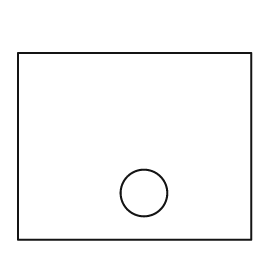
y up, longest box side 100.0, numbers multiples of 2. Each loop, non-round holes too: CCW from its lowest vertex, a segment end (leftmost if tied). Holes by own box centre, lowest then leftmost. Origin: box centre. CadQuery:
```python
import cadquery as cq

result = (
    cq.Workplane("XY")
    .moveTo(-50.0, -40.0)
    .lineTo(50.0, -40.0)
    .lineTo(50.0, 40.0)
    .lineTo(-50.0, 40.0)
    .close()
    .moveTo(4.0, -20.0)
    .circle(10.0)
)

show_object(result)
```